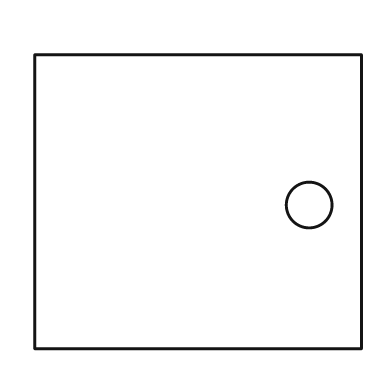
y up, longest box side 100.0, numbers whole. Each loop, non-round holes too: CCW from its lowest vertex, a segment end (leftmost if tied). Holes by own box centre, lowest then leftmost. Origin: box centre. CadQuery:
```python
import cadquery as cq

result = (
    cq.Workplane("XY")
    .moveTo(-50.0, -45.0)
    .lineTo(50.0, -45.0)
    .lineTo(50.0, 45.0)
    .lineTo(-50.0, 45.0)
    .close()
    .moveTo(34.0, -1.0)
    .circle(7.0)
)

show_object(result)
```